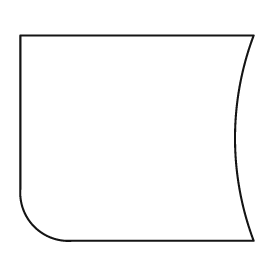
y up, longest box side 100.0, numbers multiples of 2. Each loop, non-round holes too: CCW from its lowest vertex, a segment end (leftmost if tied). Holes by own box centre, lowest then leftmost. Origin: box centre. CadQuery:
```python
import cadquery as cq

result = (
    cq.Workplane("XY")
    .moveTo(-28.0, -44.0)
    .lineTo(50.0, -44.0)
    .threePointArc((42.0, 0.0), (50.0, 44.0))
    .lineTo(-50.0, 44.0)
    .lineTo(-50.0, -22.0)
    .threePointArc((-44.0, -38.0), (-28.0, -44.0))
    .close()
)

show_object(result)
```